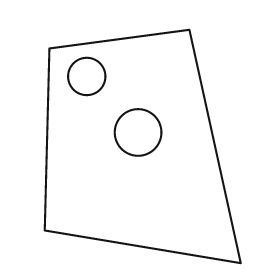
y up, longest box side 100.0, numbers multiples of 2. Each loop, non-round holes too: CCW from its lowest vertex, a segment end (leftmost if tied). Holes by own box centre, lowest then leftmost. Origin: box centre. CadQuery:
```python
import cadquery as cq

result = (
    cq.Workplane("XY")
    .moveTo(42.0, -50.0)
    .lineTo(20.0, 50.0)
    .lineTo(-40.0, 42.0)
    .lineTo(-42.0, -36.0)
    .close()
    .moveTo(-2.0, 6.0)
    .circle(10.0)
    .moveTo(-24.0, 30.0)
    .circle(8.0)
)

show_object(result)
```